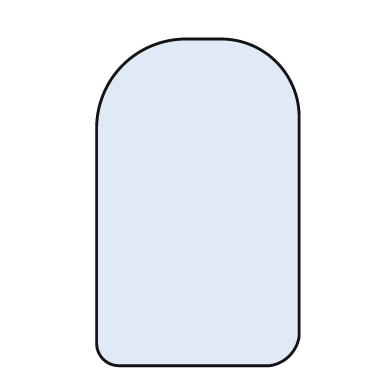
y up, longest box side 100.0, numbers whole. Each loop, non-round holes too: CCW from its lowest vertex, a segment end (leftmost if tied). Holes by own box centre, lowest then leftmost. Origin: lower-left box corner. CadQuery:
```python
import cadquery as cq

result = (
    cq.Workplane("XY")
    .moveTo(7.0, 0.0)
    .lineTo(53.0, 0.0)
    .threePointArc((59.0, 3.0), (62.0, 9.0))
    .lineTo(62.0, 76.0)
    .threePointArc((55.0, 93.0), (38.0, 100.0))
    .lineTo(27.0, 100.0)
    .threePointArc((8.0, 92.0), (0.0, 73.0))
    .lineTo(0.0, 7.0)
    .threePointArc((2.0, 2.0), (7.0, 0.0))
    .close()
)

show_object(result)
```